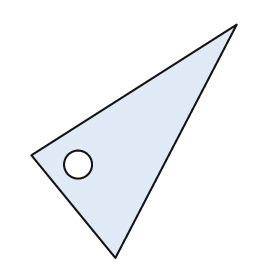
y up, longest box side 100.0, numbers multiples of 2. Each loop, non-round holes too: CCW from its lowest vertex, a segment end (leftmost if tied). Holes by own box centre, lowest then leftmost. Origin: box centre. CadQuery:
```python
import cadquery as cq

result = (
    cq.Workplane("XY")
    .moveTo(-8.0, -50.0)
    .lineTo(44.0, 50.0)
    .lineTo(-44.0, -6.0)
    .close()
    .moveTo(-24.0, -10.0)
    .circle(6.0)
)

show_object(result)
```